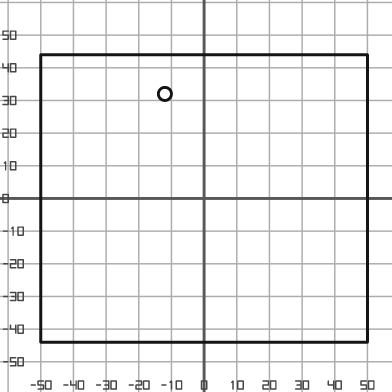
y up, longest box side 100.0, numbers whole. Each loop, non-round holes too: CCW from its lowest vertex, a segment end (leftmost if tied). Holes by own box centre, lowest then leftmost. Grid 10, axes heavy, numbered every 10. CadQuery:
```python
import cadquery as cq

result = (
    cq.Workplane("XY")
    .moveTo(-50.0, -44.0)
    .lineTo(50.0, -44.0)
    .lineTo(50.0, 44.0)
    .lineTo(-50.0, 44.0)
    .close()
    .moveTo(-12.0, 32.0)
    .circle(2.0)
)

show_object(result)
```